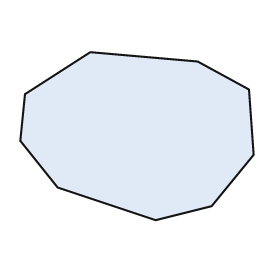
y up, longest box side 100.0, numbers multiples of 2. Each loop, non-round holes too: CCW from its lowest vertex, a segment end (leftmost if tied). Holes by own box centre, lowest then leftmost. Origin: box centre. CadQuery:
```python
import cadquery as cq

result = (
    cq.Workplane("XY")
    .moveTo(8.0, -36.0)
    .lineTo(32.0, -30.0)
    .lineTo(50.0, -8.0)
    .lineTo(48.0, 20.0)
    .lineTo(26.0, 32.0)
    .lineTo(-20.0, 36.0)
    .lineTo(-48.0, 18.0)
    .lineTo(-50.0, -2.0)
    .lineTo(-34.0, -22.0)
    .close()
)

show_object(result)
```